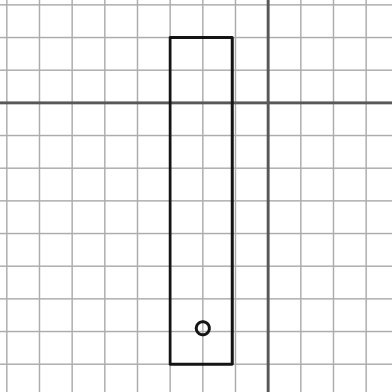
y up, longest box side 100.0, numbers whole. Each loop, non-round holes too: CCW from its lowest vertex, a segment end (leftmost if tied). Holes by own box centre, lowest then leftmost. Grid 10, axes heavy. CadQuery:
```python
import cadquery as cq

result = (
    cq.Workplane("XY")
    .moveTo(-30.0, -80.0)
    .lineTo(-11.0, -80.0)
    .lineTo(-11.0, 20.0)
    .lineTo(-30.0, 20.0)
    .close()
    .moveTo(-20.0, -69.0)
    .circle(2.0)
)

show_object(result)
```